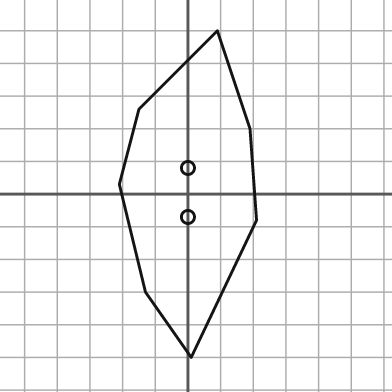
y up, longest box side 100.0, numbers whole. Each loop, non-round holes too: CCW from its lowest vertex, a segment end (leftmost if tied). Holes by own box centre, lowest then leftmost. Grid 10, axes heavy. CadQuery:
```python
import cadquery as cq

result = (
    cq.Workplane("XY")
    .moveTo(1.0, -50.0)
    .lineTo(21.0, -8.0)
    .lineTo(19.0, 20.0)
    .lineTo(9.0, 50.0)
    .lineTo(-15.0, 26.0)
    .lineTo(-21.0, 3.0)
    .lineTo(-13.0, -30.0)
    .close()
    .moveTo(0.0, -7.0)
    .circle(2.0)
    .moveTo(0.0, 8.0)
    .circle(2.0)
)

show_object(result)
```